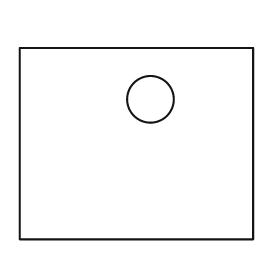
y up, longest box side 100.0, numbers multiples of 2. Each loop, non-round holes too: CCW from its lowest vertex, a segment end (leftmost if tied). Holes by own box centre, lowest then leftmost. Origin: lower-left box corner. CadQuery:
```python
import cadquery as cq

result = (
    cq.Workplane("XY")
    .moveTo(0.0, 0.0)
    .lineTo(100.0, 0.0)
    .lineTo(100.0, 82.0)
    .lineTo(0.0, 82.0)
    .close()
    .moveTo(56.0, 60.0)
    .circle(10.0)
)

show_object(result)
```